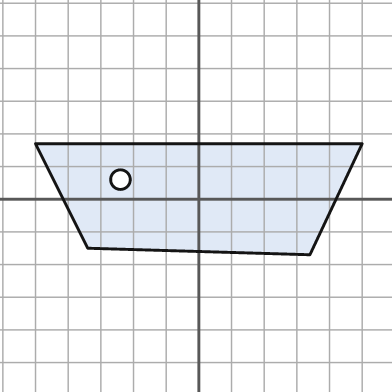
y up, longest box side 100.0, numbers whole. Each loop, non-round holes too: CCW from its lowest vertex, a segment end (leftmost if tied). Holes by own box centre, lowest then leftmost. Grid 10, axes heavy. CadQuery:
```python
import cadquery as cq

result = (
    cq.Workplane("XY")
    .moveTo(34.0, -17.0)
    .lineTo(50.0, 17.0)
    .lineTo(-50.0, 17.0)
    .lineTo(-34.0, -15.0)
    .close()
    .moveTo(-24.0, 6.0)
    .circle(3.0)
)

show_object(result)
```